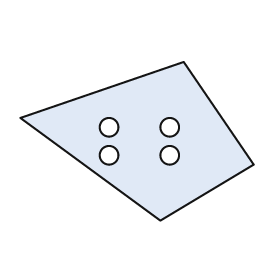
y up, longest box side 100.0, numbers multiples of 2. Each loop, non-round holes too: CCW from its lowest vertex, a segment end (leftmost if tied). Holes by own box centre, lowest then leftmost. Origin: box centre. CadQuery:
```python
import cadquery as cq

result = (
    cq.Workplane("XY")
    .moveTo(10.0, -34.0)
    .lineTo(50.0, -10.0)
    .lineTo(20.0, 34.0)
    .lineTo(-50.0, 10.0)
    .close()
    .moveTo(-12.0, -6.0)
    .circle(4.0)
    .moveTo(14.0, -6.0)
    .circle(4.0)
    .moveTo(-12.0, 6.0)
    .circle(4.0)
    .moveTo(14.0, 6.0)
    .circle(4.0)
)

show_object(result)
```